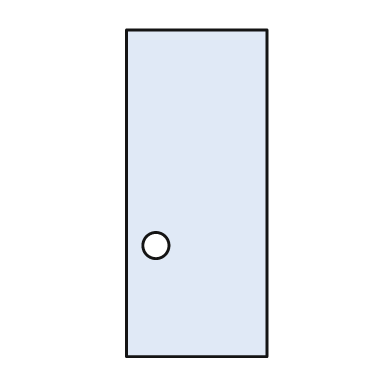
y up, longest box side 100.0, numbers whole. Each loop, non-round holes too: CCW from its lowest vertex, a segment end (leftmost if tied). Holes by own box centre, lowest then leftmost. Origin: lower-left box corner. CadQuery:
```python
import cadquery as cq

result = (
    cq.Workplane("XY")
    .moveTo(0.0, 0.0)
    .lineTo(43.0, 0.0)
    .lineTo(43.0, 100.0)
    .lineTo(0.0, 100.0)
    .close()
    .moveTo(9.0, 34.0)
    .circle(4.0)
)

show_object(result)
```